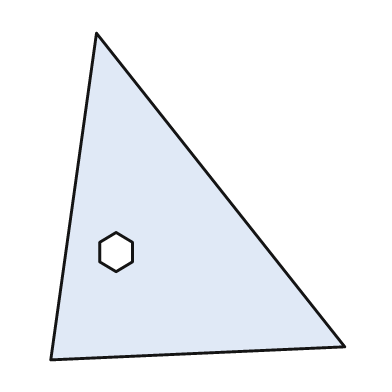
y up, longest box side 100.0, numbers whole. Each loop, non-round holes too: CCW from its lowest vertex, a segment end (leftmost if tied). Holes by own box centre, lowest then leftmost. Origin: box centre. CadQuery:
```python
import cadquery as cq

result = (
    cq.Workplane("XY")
    .moveTo(-45.0, -50.0)
    .lineTo(45.0, -46.0)
    .lineTo(-31.0, 50.0)
    .close()
    .moveTo(-25.0, -23.0)
    .lineTo(-20.0, -20.0)
    .lineTo(-20.0, -14.0)
    .lineTo(-25.0, -11.0)
    .lineTo(-30.0, -14.0)
    .lineTo(-30.0, -20.0)
    .close()
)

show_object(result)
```